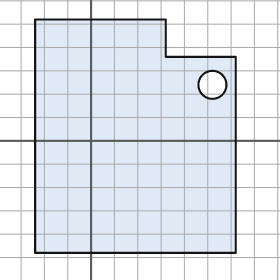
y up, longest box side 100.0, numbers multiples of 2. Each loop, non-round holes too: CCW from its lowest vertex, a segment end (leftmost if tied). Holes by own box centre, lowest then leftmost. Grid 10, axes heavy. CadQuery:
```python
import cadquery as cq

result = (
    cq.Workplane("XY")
    .moveTo(-24.0, -48.0)
    .lineTo(62.0, -48.0)
    .lineTo(62.0, 36.0)
    .lineTo(32.0, 36.0)
    .lineTo(32.0, 52.0)
    .lineTo(-24.0, 52.0)
    .close()
    .moveTo(52.0, 24.0)
    .circle(6.0)
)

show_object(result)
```